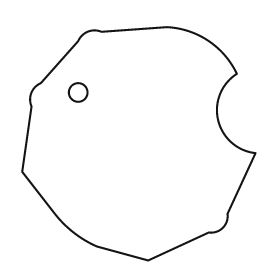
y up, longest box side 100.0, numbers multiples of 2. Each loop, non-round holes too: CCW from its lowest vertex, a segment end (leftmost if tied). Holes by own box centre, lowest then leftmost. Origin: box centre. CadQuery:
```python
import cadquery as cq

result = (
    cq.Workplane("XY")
    .moveTo(4.0, -50.0)
    .lineTo(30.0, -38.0)
    .threePointArc((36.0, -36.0), (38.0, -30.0))
    .lineTo(50.0, -4.0)
    .threePointArc((34.0, 10.0), (42.0, 30.0))
    .threePointArc((30.0, 44.0), (12.0, 50.0))
    .lineTo(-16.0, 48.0)
    .threePointArc((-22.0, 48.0), (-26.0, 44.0))
    .lineTo(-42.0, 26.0)
    .threePointArc((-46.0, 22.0), (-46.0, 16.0))
    .lineTo(-50.0, -12.0)
    .lineTo(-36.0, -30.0)
    .threePointArc((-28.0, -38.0), (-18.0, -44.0))
    .close()
    .moveTo(-26.0, 22.0)
    .circle(4.0)
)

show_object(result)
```